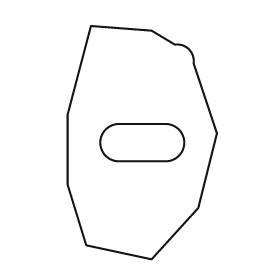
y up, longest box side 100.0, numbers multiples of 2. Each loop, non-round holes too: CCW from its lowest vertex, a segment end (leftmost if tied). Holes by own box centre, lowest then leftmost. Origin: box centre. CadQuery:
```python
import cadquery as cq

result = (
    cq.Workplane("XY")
    .moveTo(4.0, -50.0)
    .lineTo(24.0, -28.0)
    .lineTo(32.0, 4.0)
    .lineTo(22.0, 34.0)
    .threePointArc((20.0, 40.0), (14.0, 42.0))
    .lineTo(4.0, 48.0)
    .lineTo(-22.0, 50.0)
    .lineTo(-32.0, 12.0)
    .lineTo(-32.0, -18.0)
    .lineTo(-24.0, -44.0)
    .close()
    .moveTo(-10.0, -8.0)
    .lineTo(10.0, -8.0)
    .threePointArc((18.0, 0.0), (10.0, 8.0))
    .lineTo(-10.0, 8.0)
    .threePointArc((-18.0, 0.0), (-10.0, -8.0))
    .close()
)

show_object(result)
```